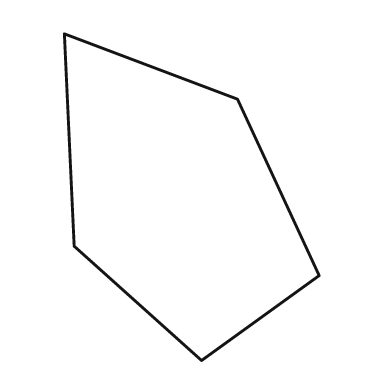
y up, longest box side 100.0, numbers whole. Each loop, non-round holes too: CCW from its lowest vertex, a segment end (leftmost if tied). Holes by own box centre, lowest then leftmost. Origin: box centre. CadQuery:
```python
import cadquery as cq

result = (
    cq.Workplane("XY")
    .moveTo(3.0, -50.0)
    .lineTo(39.0, -24.0)
    .lineTo(14.0, 30.0)
    .lineTo(-39.0, 50.0)
    .lineTo(-36.0, -15.0)
    .close()
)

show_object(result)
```